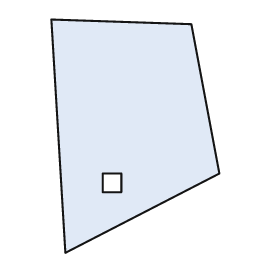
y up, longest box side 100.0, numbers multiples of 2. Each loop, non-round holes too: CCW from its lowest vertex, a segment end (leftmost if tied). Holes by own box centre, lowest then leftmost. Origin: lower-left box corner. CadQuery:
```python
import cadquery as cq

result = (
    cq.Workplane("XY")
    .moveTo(6.0, 0.0)
    .lineTo(72.0, 34.0)
    .lineTo(60.0, 98.0)
    .lineTo(0.0, 100.0)
    .close()
    .moveTo(22.0, 26.0)
    .lineTo(30.0, 26.0)
    .lineTo(30.0, 34.0)
    .lineTo(22.0, 34.0)
    .close()
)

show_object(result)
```